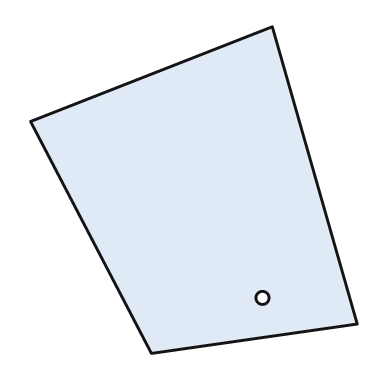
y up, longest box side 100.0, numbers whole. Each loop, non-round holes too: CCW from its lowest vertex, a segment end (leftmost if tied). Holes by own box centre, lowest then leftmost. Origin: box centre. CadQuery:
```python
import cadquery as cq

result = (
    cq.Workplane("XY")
    .moveTo(-13.0, -50.0)
    .lineTo(50.0, -41.0)
    .lineTo(24.0, 50.0)
    .lineTo(-50.0, 21.0)
    .close()
    .moveTo(21.0, -33.0)
    .circle(2.0)
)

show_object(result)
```